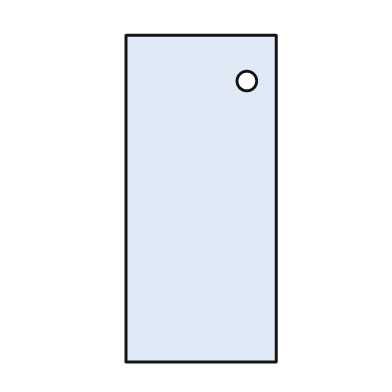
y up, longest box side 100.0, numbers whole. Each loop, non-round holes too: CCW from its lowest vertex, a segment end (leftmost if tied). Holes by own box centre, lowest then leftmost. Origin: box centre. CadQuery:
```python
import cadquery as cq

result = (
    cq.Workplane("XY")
    .moveTo(-23.0, -50.0)
    .lineTo(23.0, -50.0)
    .lineTo(23.0, 50.0)
    .lineTo(-23.0, 50.0)
    .close()
    .moveTo(14.0, 36.0)
    .circle(3.0)
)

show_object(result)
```